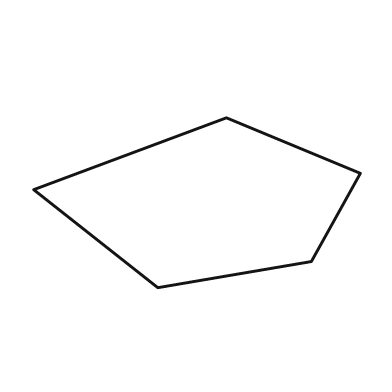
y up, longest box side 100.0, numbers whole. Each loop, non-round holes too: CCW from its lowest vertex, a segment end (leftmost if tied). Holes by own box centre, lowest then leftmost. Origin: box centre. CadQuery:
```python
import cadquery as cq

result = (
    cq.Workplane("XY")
    .moveTo(-12.0, -26.0)
    .lineTo(35.0, -18.0)
    .lineTo(50.0, 9.0)
    .lineTo(9.0, 26.0)
    .lineTo(-50.0, 4.0)
    .close()
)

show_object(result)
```